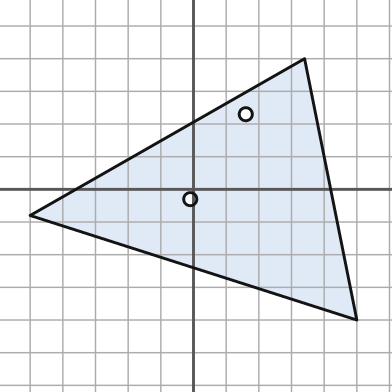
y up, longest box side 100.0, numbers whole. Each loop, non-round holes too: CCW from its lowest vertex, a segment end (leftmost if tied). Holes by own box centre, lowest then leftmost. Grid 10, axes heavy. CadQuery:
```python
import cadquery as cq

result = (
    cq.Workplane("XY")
    .moveTo(50.0, -40.0)
    .lineTo(34.0, 40.0)
    .lineTo(-50.0, -8.0)
    .close()
    .moveTo(-1.0, -3.0)
    .circle(2.0)
    .moveTo(16.0, 23.0)
    .circle(2.0)
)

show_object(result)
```